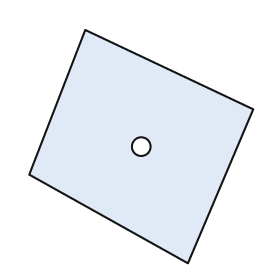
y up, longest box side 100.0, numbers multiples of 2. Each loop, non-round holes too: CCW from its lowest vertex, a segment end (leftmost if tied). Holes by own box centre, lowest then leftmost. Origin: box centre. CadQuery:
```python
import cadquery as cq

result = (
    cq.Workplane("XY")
    .moveTo(20.0, -50.0)
    .lineTo(48.0, 16.0)
    .lineTo(-24.0, 50.0)
    .lineTo(-48.0, -12.0)
    .close()
    .moveTo(0.0, 0.0)
    .circle(4.0)
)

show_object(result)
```